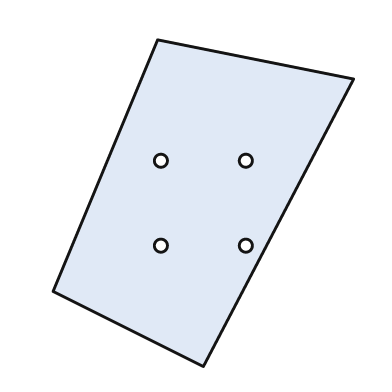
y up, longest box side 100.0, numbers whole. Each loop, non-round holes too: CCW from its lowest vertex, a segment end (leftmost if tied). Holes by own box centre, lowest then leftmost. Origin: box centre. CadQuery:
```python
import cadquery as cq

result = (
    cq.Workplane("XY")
    .moveTo(0.0, -50.0)
    .lineTo(46.0, 38.0)
    .lineTo(-14.0, 50.0)
    .lineTo(-46.0, -27.0)
    .close()
    .moveTo(-13.0, -13.0)
    .circle(2.0)
    .moveTo(13.0, -13.0)
    .circle(2.0)
    .moveTo(-13.0, 13.0)
    .circle(2.0)
    .moveTo(13.0, 13.0)
    .circle(2.0)
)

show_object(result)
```